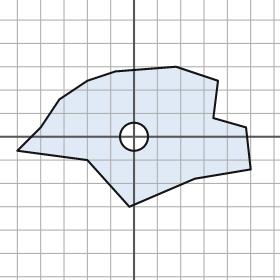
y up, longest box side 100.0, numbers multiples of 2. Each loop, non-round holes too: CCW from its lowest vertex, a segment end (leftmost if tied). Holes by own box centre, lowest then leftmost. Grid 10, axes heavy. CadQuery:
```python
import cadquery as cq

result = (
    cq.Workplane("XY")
    .moveTo(-2.0, -30.0)
    .lineTo(26.0, -18.0)
    .lineTo(50.0, -14.0)
    .lineTo(48.0, 4.0)
    .lineTo(34.0, 8.0)
    .lineTo(36.0, 24.0)
    .lineTo(18.0, 30.0)
    .lineTo(-8.0, 28.0)
    .lineTo(-20.0, 24.0)
    .lineTo(-32.0, 16.0)
    .lineTo(-40.0, 4.0)
    .lineTo(-50.0, -6.0)
    .lineTo(-20.0, -10.0)
    .close()
    .moveTo(0.0, 0.0)
    .circle(6.0)
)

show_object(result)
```